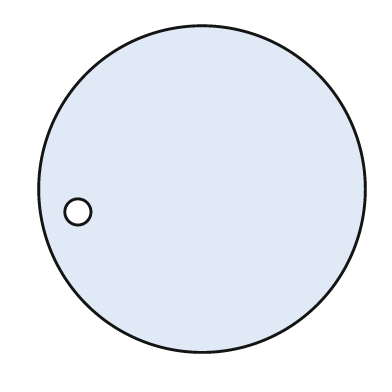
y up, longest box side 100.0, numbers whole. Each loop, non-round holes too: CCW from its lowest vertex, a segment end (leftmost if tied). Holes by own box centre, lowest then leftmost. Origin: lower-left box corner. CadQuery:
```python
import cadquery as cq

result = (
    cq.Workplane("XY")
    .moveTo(50.0, 50.0)
    .circle(50.0)
    .moveTo(12.0, 43.0)
    .circle(4.0)
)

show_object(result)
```